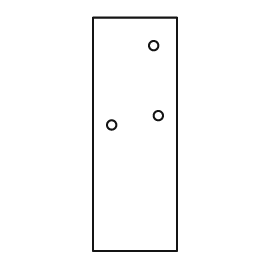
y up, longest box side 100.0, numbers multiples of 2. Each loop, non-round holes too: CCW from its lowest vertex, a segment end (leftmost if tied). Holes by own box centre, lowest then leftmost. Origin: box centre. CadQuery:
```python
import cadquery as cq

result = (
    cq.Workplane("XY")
    .moveTo(-18.0, -50.0)
    .lineTo(18.0, -50.0)
    .lineTo(18.0, 50.0)
    .lineTo(-18.0, 50.0)
    .close()
    .moveTo(-10.0, 4.0)
    .circle(2.0)
    .moveTo(10.0, 8.0)
    .circle(2.0)
    .moveTo(8.0, 38.0)
    .circle(2.0)
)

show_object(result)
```